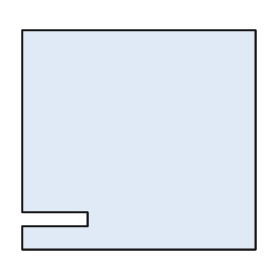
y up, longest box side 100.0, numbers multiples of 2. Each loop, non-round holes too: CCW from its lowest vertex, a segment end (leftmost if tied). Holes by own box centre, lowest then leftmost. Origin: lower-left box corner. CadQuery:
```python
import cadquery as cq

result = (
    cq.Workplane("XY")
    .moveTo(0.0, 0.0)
    .lineTo(100.0, 0.0)
    .lineTo(100.0, 94.0)
    .lineTo(0.0, 94.0)
    .lineTo(0.0, 16.0)
    .lineTo(28.0, 16.0)
    .lineTo(28.0, 10.0)
    .lineTo(0.0, 10.0)
    .close()
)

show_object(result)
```